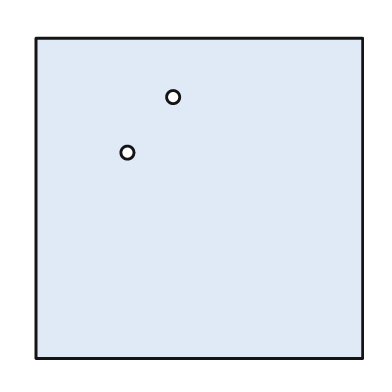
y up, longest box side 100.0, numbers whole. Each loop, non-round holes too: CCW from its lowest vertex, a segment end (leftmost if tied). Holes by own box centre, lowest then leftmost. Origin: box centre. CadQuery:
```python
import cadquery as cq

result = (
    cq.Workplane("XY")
    .moveTo(-50.0, -49.0)
    .lineTo(50.0, -49.0)
    .lineTo(50.0, 49.0)
    .lineTo(-50.0, 49.0)
    .close()
    .moveTo(-22.0, 14.0)
    .circle(2.0)
    .moveTo(-8.0, 31.0)
    .circle(2.0)
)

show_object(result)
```